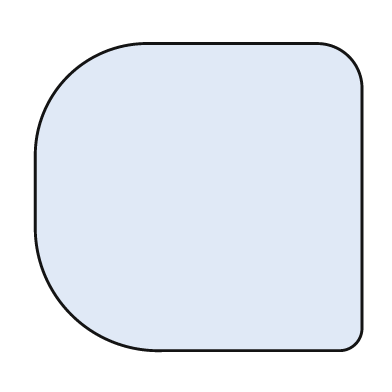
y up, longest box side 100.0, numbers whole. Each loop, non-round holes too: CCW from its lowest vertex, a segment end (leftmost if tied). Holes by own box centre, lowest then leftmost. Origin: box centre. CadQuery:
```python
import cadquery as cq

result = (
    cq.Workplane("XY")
    .moveTo(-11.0, -47.0)
    .lineTo(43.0, -47.0)
    .threePointArc((48.0, -45.0), (50.0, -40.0))
    .lineTo(50.0, 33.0)
    .threePointArc((46.0, 43.0), (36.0, 47.0))
    .lineTo(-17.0, 47.0)
    .threePointArc((-40.0, 37.0), (-50.0, 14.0))
    .lineTo(-50.0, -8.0)
    .threePointArc((-39.0, -36.0), (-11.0, -47.0))
    .close()
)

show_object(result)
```